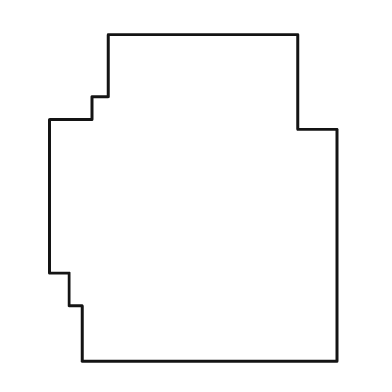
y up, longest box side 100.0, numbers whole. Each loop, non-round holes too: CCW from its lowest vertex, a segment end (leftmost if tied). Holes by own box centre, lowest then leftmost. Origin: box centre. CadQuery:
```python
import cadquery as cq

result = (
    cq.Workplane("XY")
    .moveTo(-34.0, -50.0)
    .lineTo(44.0, -50.0)
    .lineTo(44.0, 21.0)
    .lineTo(32.0, 21.0)
    .lineTo(32.0, 50.0)
    .lineTo(-26.0, 50.0)
    .lineTo(-26.0, 31.0)
    .lineTo(-31.0, 31.0)
    .lineTo(-31.0, 24.0)
    .lineTo(-44.0, 24.0)
    .lineTo(-44.0, -23.0)
    .lineTo(-38.0, -23.0)
    .lineTo(-38.0, -33.0)
    .lineTo(-34.0, -33.0)
    .close()
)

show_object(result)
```